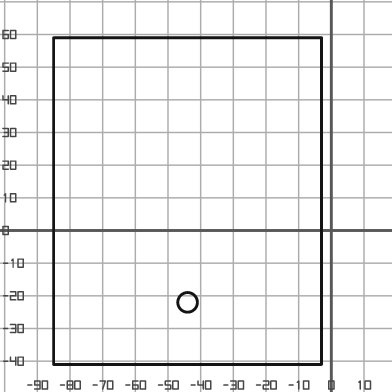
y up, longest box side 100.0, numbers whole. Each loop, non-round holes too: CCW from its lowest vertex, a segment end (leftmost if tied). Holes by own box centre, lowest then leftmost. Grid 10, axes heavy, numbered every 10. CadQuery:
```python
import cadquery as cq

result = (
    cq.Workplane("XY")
    .moveTo(-85.0, -41.0)
    .lineTo(-3.0, -41.0)
    .lineTo(-3.0, 59.0)
    .lineTo(-85.0, 59.0)
    .close()
    .moveTo(-44.0, -22.0)
    .circle(3.0)
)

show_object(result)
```